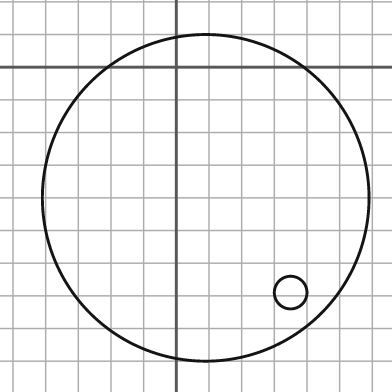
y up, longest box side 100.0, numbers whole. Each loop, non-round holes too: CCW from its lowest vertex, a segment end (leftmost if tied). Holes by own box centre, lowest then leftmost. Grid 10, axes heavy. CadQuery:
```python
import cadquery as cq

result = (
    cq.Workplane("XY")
    .moveTo(9.0, -40.0)
    .circle(50.0)
    .moveTo(35.0, -69.0)
    .circle(5.0)
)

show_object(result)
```